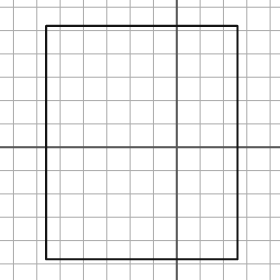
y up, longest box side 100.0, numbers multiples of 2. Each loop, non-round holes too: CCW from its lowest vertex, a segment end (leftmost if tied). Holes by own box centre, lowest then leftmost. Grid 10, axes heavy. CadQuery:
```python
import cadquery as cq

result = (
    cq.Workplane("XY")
    .moveTo(-56.0, -48.0)
    .lineTo(26.0, -48.0)
    .lineTo(26.0, 52.0)
    .lineTo(-56.0, 52.0)
    .close()
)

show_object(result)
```